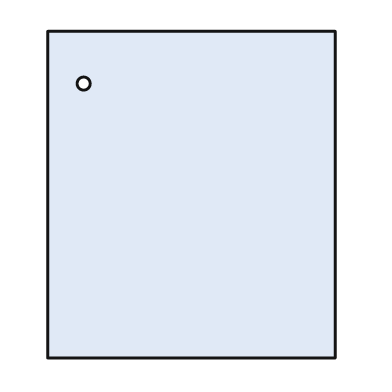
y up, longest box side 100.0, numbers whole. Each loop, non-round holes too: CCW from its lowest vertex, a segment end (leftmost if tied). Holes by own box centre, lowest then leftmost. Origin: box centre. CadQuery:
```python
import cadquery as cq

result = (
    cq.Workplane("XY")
    .moveTo(-44.0, -50.0)
    .lineTo(44.0, -50.0)
    .lineTo(44.0, 50.0)
    .lineTo(-44.0, 50.0)
    .close()
    .moveTo(-33.0, 34.0)
    .circle(2.0)
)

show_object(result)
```